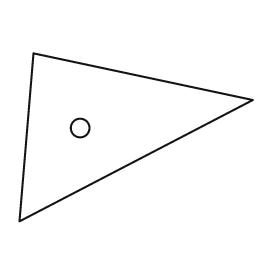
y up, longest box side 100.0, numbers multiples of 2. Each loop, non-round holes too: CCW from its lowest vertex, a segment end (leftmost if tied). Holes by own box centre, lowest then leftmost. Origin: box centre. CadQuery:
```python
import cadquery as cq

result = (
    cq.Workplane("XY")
    .moveTo(-50.0, -36.0)
    .lineTo(50.0, 16.0)
    .lineTo(-44.0, 36.0)
    .close()
    .moveTo(-24.0, 4.0)
    .circle(4.0)
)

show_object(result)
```